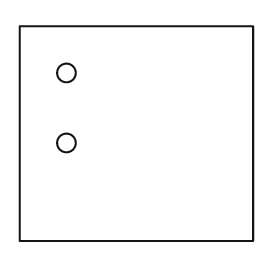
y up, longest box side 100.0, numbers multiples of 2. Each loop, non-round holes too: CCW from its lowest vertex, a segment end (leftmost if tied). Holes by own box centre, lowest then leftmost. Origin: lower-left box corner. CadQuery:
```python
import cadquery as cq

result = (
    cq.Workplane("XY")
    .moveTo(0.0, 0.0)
    .lineTo(100.0, 0.0)
    .lineTo(100.0, 92.0)
    .lineTo(0.0, 92.0)
    .close()
    .moveTo(20.0, 42.0)
    .circle(4.0)
    .moveTo(20.0, 72.0)
    .circle(4.0)
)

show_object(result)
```